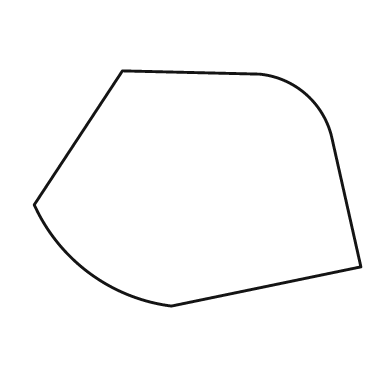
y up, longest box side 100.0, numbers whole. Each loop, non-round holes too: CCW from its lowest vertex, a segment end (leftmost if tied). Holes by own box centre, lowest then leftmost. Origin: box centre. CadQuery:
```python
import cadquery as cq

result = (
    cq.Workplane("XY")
    .moveTo(-8.0, -36.0)
    .lineTo(50.0, -24.0)
    .lineTo(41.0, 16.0)
    .threePointArc((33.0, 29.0), (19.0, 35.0))
    .lineTo(-23.0, 36.0)
    .lineTo(-50.0, -5.0)
    .threePointArc((-33.0, -26.0), (-8.0, -36.0))
    .close()
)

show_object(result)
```